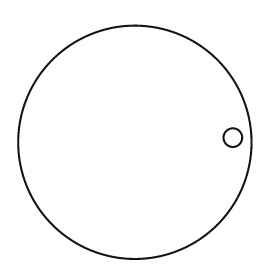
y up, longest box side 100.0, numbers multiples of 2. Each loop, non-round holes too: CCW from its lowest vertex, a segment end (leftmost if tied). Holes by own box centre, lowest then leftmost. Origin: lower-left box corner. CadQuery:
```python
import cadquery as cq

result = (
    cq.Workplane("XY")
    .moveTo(50.0, 50.0)
    .circle(50.0)
    .moveTo(92.0, 52.0)
    .circle(4.0)
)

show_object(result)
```